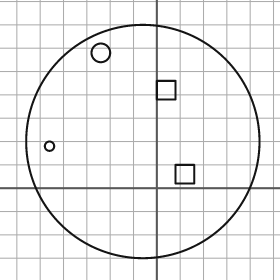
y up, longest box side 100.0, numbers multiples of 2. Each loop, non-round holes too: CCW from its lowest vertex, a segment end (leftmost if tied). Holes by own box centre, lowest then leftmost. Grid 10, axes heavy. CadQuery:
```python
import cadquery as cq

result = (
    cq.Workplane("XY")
    .moveTo(-6.0, 20.0)
    .circle(50.0)
    .moveTo(8.0, 2.0)
    .lineTo(16.0, 2.0)
    .lineTo(16.0, 10.0)
    .lineTo(8.0, 10.0)
    .close()
    .moveTo(-46.0, 18.0)
    .circle(2.0)
    .moveTo(0.0, 38.0)
    .lineTo(8.0, 38.0)
    .lineTo(8.0, 46.0)
    .lineTo(0.0, 46.0)
    .close()
    .moveTo(-24.0, 58.0)
    .circle(4.0)
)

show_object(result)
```